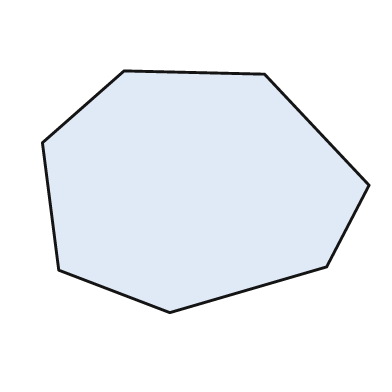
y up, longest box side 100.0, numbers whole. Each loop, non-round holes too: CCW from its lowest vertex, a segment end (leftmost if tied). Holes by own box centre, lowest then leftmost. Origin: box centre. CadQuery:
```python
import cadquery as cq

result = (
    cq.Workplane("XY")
    .moveTo(-11.0, -37.0)
    .lineTo(37.0, -23.0)
    .lineTo(50.0, 2.0)
    .lineTo(18.0, 36.0)
    .lineTo(-25.0, 37.0)
    .lineTo(-50.0, 15.0)
    .lineTo(-45.0, -24.0)
    .close()
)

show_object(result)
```